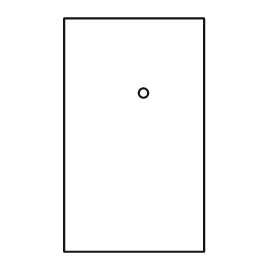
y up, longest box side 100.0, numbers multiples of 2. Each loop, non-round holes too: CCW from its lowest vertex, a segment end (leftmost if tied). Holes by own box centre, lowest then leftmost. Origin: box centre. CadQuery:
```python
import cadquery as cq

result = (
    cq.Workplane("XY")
    .moveTo(-30.0, -50.0)
    .lineTo(30.0, -50.0)
    .lineTo(30.0, 50.0)
    .lineTo(-30.0, 50.0)
    .close()
    .moveTo(4.0, 18.0)
    .circle(2.0)
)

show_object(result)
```